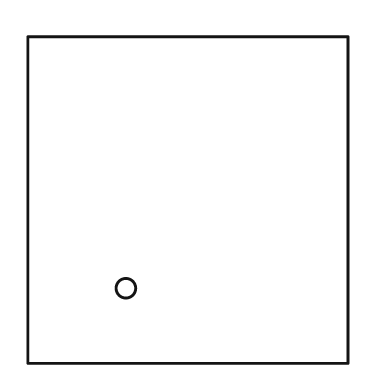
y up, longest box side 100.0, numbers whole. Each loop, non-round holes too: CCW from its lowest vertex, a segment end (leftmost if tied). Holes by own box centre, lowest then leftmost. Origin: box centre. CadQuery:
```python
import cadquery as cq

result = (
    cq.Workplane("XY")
    .moveTo(-49.0, -50.0)
    .lineTo(49.0, -50.0)
    .lineTo(49.0, 50.0)
    .lineTo(-49.0, 50.0)
    .close()
    .moveTo(-19.0, -27.0)
    .circle(3.0)
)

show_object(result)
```